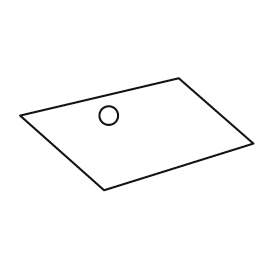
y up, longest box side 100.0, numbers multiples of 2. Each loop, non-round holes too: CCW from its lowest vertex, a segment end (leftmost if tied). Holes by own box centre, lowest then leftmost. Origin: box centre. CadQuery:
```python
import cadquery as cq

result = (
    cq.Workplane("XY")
    .moveTo(-14.0, -24.0)
    .lineTo(50.0, -4.0)
    .lineTo(18.0, 24.0)
    .lineTo(-50.0, 8.0)
    .close()
    .moveTo(-12.0, 8.0)
    .circle(4.0)
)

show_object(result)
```